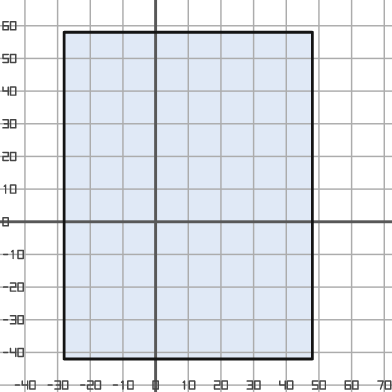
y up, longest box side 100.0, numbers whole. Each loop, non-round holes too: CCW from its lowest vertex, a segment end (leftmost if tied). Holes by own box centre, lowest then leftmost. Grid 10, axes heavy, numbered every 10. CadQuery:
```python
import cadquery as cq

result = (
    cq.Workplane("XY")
    .moveTo(-28.0, -42.0)
    .lineTo(48.0, -42.0)
    .lineTo(48.0, 58.0)
    .lineTo(-28.0, 58.0)
    .close()
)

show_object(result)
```